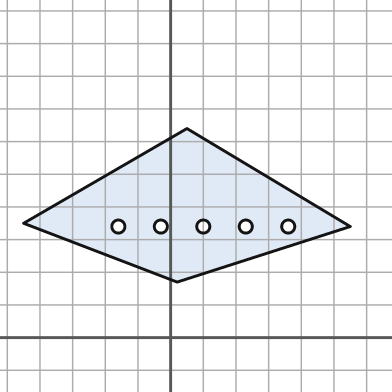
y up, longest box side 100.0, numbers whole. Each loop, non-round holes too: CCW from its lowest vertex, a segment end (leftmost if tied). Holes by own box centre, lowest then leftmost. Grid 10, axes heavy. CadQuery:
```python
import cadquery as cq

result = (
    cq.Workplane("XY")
    .moveTo(2.0, 17.0)
    .lineTo(55.0, 34.0)
    .lineTo(5.0, 64.0)
    .lineTo(-45.0, 35.0)
    .close()
    .moveTo(-16.0, 34.0)
    .circle(2.0)
    .moveTo(-3.0, 34.0)
    .circle(2.0)
    .moveTo(10.0, 34.0)
    .circle(2.0)
    .moveTo(23.0, 34.0)
    .circle(2.0)
    .moveTo(36.0, 34.0)
    .circle(2.0)
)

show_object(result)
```